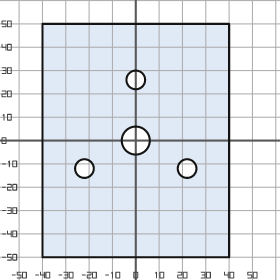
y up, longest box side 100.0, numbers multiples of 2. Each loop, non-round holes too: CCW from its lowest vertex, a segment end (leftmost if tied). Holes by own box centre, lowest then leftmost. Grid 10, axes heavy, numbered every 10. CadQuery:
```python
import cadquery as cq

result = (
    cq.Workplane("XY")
    .moveTo(-40.0, -50.0)
    .lineTo(40.0, -50.0)
    .lineTo(40.0, 50.0)
    .lineTo(-40.0, 50.0)
    .close()
    .moveTo(-22.0, -12.0)
    .circle(4.0)
    .moveTo(22.0, -12.0)
    .circle(4.0)
    .moveTo(0.0, 0.0)
    .circle(6.0)
    .moveTo(0.0, 26.0)
    .circle(4.0)
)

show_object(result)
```